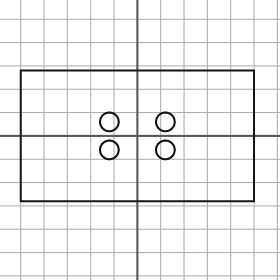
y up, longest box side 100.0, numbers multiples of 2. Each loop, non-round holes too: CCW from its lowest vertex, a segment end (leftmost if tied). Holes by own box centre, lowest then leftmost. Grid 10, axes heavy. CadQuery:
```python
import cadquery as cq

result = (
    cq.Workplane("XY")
    .moveTo(-50.0, -28.0)
    .lineTo(50.0, -28.0)
    .lineTo(50.0, 28.0)
    .lineTo(-50.0, 28.0)
    .close()
    .moveTo(-12.0, -6.0)
    .circle(4.0)
    .moveTo(12.0, -6.0)
    .circle(4.0)
    .moveTo(-12.0, 6.0)
    .circle(4.0)
    .moveTo(12.0, 6.0)
    .circle(4.0)
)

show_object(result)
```